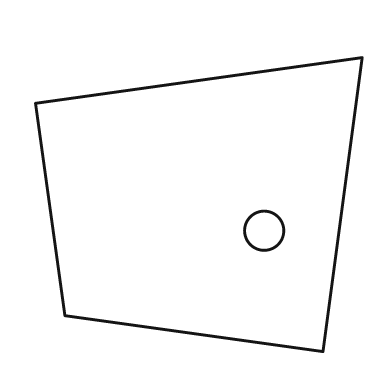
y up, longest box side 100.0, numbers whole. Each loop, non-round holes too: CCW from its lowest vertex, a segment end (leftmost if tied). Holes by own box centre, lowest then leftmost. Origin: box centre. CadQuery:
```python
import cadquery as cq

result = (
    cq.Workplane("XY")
    .moveTo(38.0, -45.0)
    .lineTo(50.0, 45.0)
    .lineTo(-50.0, 31.0)
    .lineTo(-41.0, -34.0)
    .close()
    .moveTo(20.0, -8.0)
    .circle(6.0)
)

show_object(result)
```